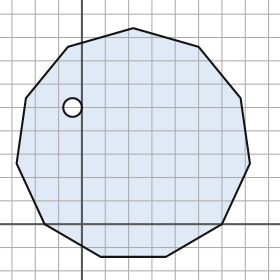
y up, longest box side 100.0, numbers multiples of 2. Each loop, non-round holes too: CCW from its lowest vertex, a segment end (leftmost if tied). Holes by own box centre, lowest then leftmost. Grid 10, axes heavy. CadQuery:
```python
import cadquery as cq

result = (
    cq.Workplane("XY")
    .moveTo(8.0, -14.0)
    .lineTo(36.0, -14.0)
    .lineTo(60.0, 0.0)
    .lineTo(72.0, 26.0)
    .lineTo(68.0, 54.0)
    .lineTo(50.0, 76.0)
    .lineTo(22.0, 84.0)
    .lineTo(-6.0, 76.0)
    .lineTo(-24.0, 54.0)
    .lineTo(-28.0, 26.0)
    .lineTo(-16.0, 0.0)
    .close()
    .moveTo(-4.0, 50.0)
    .circle(4.0)
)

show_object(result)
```